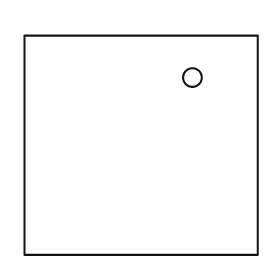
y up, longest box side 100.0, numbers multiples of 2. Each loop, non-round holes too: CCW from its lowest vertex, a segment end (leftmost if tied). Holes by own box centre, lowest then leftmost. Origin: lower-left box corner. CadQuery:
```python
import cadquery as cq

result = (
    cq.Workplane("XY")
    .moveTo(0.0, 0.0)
    .lineTo(100.0, 0.0)
    .lineTo(100.0, 94.0)
    .lineTo(0.0, 94.0)
    .close()
    .moveTo(72.0, 76.0)
    .circle(4.0)
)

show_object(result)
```